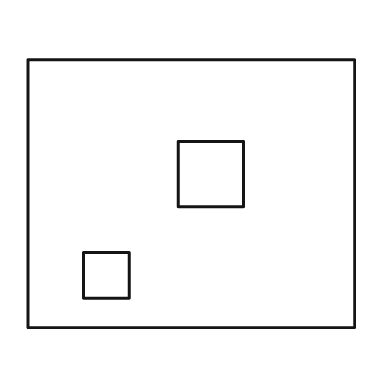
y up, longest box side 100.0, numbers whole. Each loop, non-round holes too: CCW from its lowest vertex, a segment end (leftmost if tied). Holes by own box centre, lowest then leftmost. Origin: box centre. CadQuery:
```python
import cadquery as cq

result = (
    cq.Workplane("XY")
    .moveTo(-50.0, -41.0)
    .lineTo(50.0, -41.0)
    .lineTo(50.0, 41.0)
    .lineTo(-50.0, 41.0)
    .close()
    .moveTo(-33.0, -32.0)
    .lineTo(-19.0, -32.0)
    .lineTo(-19.0, -18.0)
    .lineTo(-33.0, -18.0)
    .close()
    .moveTo(-4.0, -4.0)
    .lineTo(16.0, -4.0)
    .lineTo(16.0, 16.0)
    .lineTo(-4.0, 16.0)
    .close()
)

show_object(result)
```